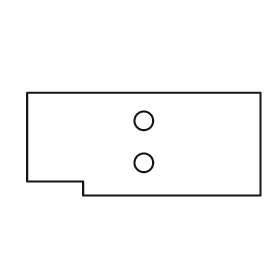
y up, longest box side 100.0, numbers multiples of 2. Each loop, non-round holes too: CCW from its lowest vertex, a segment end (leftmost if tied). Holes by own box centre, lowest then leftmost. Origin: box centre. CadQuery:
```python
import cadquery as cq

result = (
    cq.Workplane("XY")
    .moveTo(-26.0, -22.0)
    .lineTo(50.0, -22.0)
    .lineTo(50.0, 22.0)
    .lineTo(-50.0, 22.0)
    .lineTo(-50.0, -16.0)
    .lineTo(-26.0, -16.0)
    .close()
    .moveTo(0.0, -8.0)
    .circle(4.0)
    .moveTo(0.0, 10.0)
    .circle(4.0)
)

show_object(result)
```